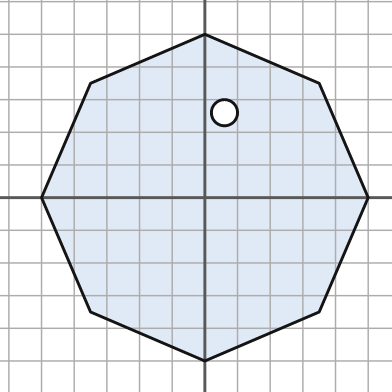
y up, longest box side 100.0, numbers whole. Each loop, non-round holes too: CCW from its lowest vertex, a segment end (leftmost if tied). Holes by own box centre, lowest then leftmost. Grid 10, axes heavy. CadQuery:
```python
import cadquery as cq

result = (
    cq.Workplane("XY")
    .moveTo(0.0, -50.0)
    .lineTo(35.0, -35.0)
    .lineTo(50.0, 0.0)
    .lineTo(35.0, 35.0)
    .lineTo(0.0, 50.0)
    .lineTo(-35.0, 35.0)
    .lineTo(-50.0, 0.0)
    .lineTo(-35.0, -35.0)
    .close()
    .moveTo(6.0, 26.0)
    .circle(4.0)
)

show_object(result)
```